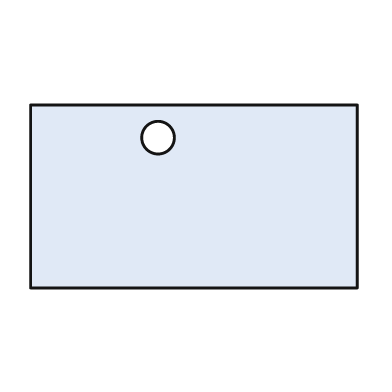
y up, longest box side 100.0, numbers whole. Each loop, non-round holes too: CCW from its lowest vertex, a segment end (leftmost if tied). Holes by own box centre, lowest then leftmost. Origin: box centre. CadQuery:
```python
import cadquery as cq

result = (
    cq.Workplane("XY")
    .moveTo(-50.0, -28.0)
    .lineTo(50.0, -28.0)
    .lineTo(50.0, 28.0)
    .lineTo(-50.0, 28.0)
    .close()
    .moveTo(-11.0, 18.0)
    .circle(5.0)
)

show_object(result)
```